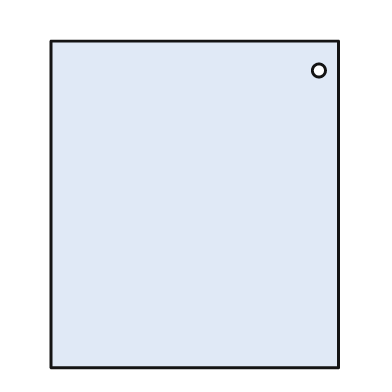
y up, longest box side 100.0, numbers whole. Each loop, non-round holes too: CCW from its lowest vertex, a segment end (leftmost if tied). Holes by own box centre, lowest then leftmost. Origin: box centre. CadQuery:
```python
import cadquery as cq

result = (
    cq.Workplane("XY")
    .moveTo(-44.0, -50.0)
    .lineTo(44.0, -50.0)
    .lineTo(44.0, 50.0)
    .lineTo(-44.0, 50.0)
    .close()
    .moveTo(38.0, 41.0)
    .circle(2.0)
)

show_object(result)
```